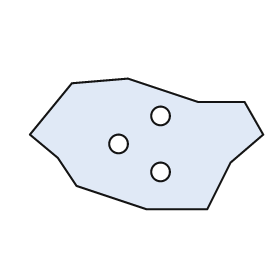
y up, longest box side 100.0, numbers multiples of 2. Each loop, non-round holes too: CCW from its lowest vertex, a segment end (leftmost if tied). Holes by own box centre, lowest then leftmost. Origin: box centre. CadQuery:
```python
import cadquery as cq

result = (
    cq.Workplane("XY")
    .moveTo(0.0, -28.0)
    .lineTo(26.0, -28.0)
    .lineTo(36.0, -8.0)
    .lineTo(50.0, 4.0)
    .lineTo(42.0, 18.0)
    .lineTo(22.0, 18.0)
    .lineTo(-8.0, 28.0)
    .lineTo(-32.0, 26.0)
    .lineTo(-50.0, 4.0)
    .lineTo(-38.0, -6.0)
    .lineTo(-30.0, -18.0)
    .close()
    .moveTo(6.0, -12.0)
    .circle(4.0)
    .moveTo(-12.0, 0.0)
    .circle(4.0)
    .moveTo(6.0, 12.0)
    .circle(4.0)
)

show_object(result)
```